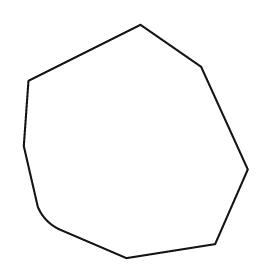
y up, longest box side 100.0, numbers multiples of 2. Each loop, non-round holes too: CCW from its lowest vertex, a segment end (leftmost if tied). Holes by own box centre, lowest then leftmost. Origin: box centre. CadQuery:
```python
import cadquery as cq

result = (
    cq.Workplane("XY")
    .moveTo(-4.0, -50.0)
    .lineTo(34.0, -44.0)
    .lineTo(48.0, -12.0)
    .lineTo(28.0, 32.0)
    .lineTo(2.0, 50.0)
    .lineTo(-46.0, 26.0)
    .lineTo(-48.0, -2.0)
    .lineTo(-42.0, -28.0)
    .threePointArc((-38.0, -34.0), (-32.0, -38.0))
    .close()
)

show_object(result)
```